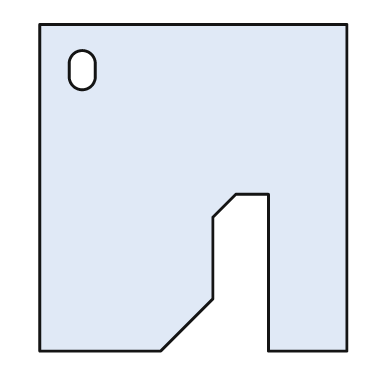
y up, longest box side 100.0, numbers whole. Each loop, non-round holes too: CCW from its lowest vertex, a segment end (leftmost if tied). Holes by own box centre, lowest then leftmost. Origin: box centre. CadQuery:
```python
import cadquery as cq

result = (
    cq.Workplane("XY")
    .moveTo(-47.0, -50.0)
    .lineTo(-10.0, -50.0)
    .lineTo(6.0, -34.0)
    .lineTo(6.0, -9.0)
    .lineTo(13.0, -2.0)
    .lineTo(23.0, -2.0)
    .lineTo(23.0, -50.0)
    .lineTo(47.0, -50.0)
    .lineTo(47.0, 50.0)
    .lineTo(-47.0, 50.0)
    .close()
    .moveTo(-38.0, 34.0)
    .threePointArc((-34.0, 30.0), (-30.0, 34.0))
    .lineTo(-30.0, 38.0)
    .threePointArc((-34.0, 42.0), (-38.0, 38.0))
    .close()
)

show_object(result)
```